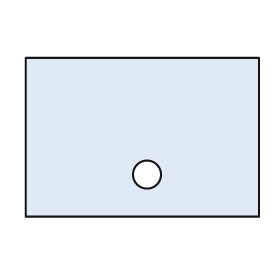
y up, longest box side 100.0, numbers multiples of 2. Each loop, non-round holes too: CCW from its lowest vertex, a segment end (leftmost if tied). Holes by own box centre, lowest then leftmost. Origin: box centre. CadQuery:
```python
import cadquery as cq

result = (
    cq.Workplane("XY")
    .moveTo(-50.0, -34.0)
    .lineTo(50.0, -34.0)
    .lineTo(50.0, 34.0)
    .lineTo(-50.0, 34.0)
    .close()
    .moveTo(2.0, -16.0)
    .circle(6.0)
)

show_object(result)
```